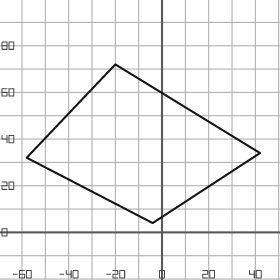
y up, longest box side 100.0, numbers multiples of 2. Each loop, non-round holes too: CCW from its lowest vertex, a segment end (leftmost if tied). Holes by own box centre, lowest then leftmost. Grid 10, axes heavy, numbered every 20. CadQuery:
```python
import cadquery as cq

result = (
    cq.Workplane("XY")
    .moveTo(-4.0, 4.0)
    .lineTo(42.0, 34.0)
    .lineTo(-20.0, 72.0)
    .lineTo(-58.0, 32.0)
    .close()
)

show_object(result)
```